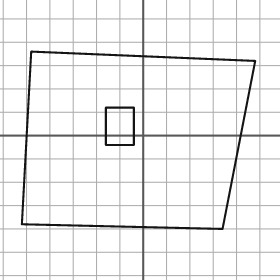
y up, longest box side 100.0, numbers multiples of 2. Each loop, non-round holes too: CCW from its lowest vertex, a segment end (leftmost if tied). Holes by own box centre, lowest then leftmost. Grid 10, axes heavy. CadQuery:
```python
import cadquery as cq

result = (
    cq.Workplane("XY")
    .moveTo(34.0, -40.0)
    .lineTo(48.0, 32.0)
    .lineTo(-48.0, 36.0)
    .lineTo(-52.0, -38.0)
    .close()
    .moveTo(-16.0, -4.0)
    .lineTo(-4.0, -4.0)
    .lineTo(-4.0, 12.0)
    .lineTo(-16.0, 12.0)
    .close()
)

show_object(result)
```